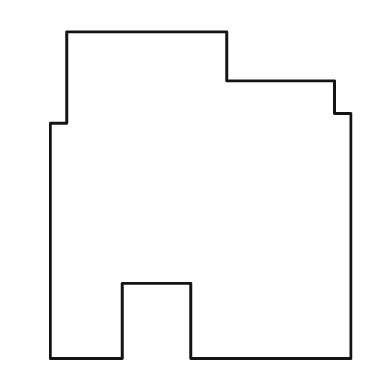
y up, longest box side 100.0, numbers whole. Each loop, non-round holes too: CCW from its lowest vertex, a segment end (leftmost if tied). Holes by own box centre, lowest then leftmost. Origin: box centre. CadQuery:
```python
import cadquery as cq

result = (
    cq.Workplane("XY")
    .moveTo(-46.0, -50.0)
    .lineTo(-24.0, -50.0)
    .lineTo(-24.0, -27.0)
    .lineTo(-3.0, -27.0)
    .lineTo(-3.0, -50.0)
    .lineTo(46.0, -50.0)
    .lineTo(46.0, 25.0)
    .lineTo(41.0, 25.0)
    .lineTo(41.0, 35.0)
    .lineTo(8.0, 35.0)
    .lineTo(8.0, 50.0)
    .lineTo(-41.0, 50.0)
    .lineTo(-41.0, 22.0)
    .lineTo(-46.0, 22.0)
    .close()
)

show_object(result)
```